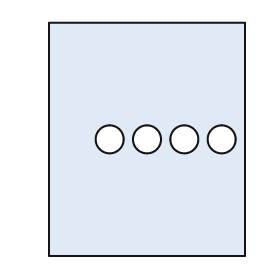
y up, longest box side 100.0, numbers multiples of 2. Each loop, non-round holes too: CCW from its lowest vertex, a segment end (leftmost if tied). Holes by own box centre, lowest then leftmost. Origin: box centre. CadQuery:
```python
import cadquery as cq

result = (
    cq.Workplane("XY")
    .moveTo(-42.0, -50.0)
    .lineTo(42.0, -50.0)
    .lineTo(42.0, 50.0)
    .lineTo(-42.0, 50.0)
    .close()
    .moveTo(-16.0, 0.0)
    .circle(6.0)
    .moveTo(0.0, 0.0)
    .circle(6.0)
    .moveTo(16.0, 0.0)
    .circle(6.0)
    .moveTo(32.0, 0.0)
    .circle(6.0)
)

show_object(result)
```